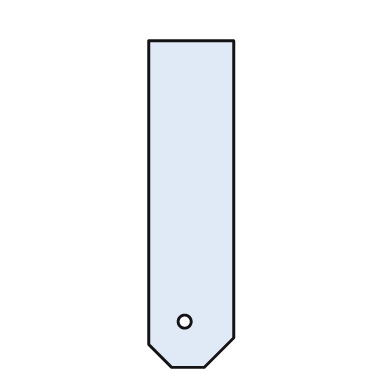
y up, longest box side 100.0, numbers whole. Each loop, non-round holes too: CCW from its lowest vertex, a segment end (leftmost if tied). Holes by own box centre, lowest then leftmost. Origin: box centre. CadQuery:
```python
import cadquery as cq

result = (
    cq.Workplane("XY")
    .moveTo(-6.0, -50.0)
    .lineTo(4.0, -50.0)
    .lineTo(13.0, -41.0)
    .lineTo(13.0, 50.0)
    .lineTo(-13.0, 50.0)
    .lineTo(-13.0, -43.0)
    .close()
    .moveTo(-2.0, -36.0)
    .circle(2.0)
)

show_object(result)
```